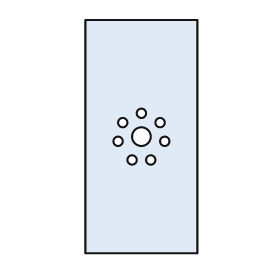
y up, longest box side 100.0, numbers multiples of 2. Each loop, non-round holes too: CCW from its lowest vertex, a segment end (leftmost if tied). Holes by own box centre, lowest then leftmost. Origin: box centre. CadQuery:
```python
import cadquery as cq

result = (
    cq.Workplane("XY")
    .moveTo(-24.0, -50.0)
    .lineTo(24.0, -50.0)
    .lineTo(24.0, 50.0)
    .lineTo(-24.0, 50.0)
    .close()
    .moveTo(-4.0, -10.0)
    .circle(2.0)
    .moveTo(4.0, -10.0)
    .circle(2.0)
    .moveTo(-10.0, -2.0)
    .circle(2.0)
    .moveTo(10.0, -2.0)
    .circle(2.0)
    .moveTo(0.0, 0.0)
    .circle(4.0)
    .moveTo(-8.0, 6.0)
    .circle(2.0)
    .moveTo(8.0, 6.0)
    .circle(2.0)
    .moveTo(0.0, 10.0)
    .circle(2.0)
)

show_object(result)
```